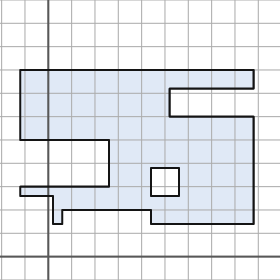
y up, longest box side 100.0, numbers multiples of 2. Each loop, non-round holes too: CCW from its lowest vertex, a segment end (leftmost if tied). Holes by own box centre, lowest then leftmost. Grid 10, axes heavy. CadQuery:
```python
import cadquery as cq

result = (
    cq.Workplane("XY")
    .moveTo(2.0, 14.0)
    .lineTo(6.0, 14.0)
    .lineTo(6.0, 20.0)
    .lineTo(44.0, 20.0)
    .lineTo(44.0, 14.0)
    .lineTo(88.0, 14.0)
    .lineTo(88.0, 60.0)
    .lineTo(52.0, 60.0)
    .lineTo(52.0, 72.0)
    .lineTo(88.0, 72.0)
    .lineTo(88.0, 80.0)
    .lineTo(-12.0, 80.0)
    .lineTo(-12.0, 50.0)
    .lineTo(26.0, 50.0)
    .lineTo(26.0, 30.0)
    .lineTo(-12.0, 30.0)
    .lineTo(-12.0, 26.0)
    .lineTo(2.0, 26.0)
    .close()
    .moveTo(44.0, 26.0)
    .lineTo(56.0, 26.0)
    .lineTo(56.0, 38.0)
    .lineTo(44.0, 38.0)
    .close()
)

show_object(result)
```